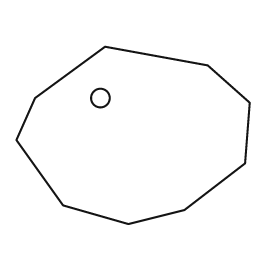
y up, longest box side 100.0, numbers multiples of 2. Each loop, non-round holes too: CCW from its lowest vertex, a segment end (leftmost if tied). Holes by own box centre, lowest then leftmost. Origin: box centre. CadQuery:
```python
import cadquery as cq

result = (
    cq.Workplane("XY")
    .moveTo(-2.0, -38.0)
    .lineTo(22.0, -32.0)
    .lineTo(48.0, -12.0)
    .lineTo(50.0, 14.0)
    .lineTo(32.0, 30.0)
    .lineTo(-12.0, 38.0)
    .lineTo(-42.0, 16.0)
    .lineTo(-50.0, -2.0)
    .lineTo(-30.0, -30.0)
    .close()
    .moveTo(-14.0, 16.0)
    .circle(4.0)
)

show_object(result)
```